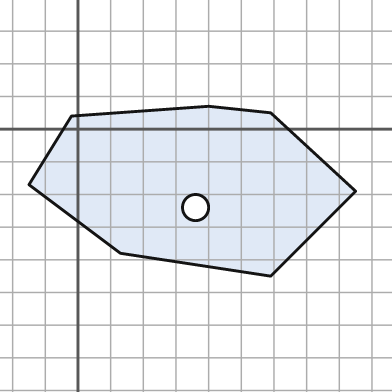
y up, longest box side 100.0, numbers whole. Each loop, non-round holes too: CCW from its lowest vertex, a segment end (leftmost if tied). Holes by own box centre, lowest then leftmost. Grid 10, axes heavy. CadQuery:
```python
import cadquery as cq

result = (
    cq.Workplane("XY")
    .moveTo(59.0, -45.0)
    .lineTo(85.0, -19.0)
    .lineTo(59.0, 5.0)
    .lineTo(40.0, 7.0)
    .lineTo(-2.0, 4.0)
    .lineTo(-15.0, -17.0)
    .lineTo(13.0, -38.0)
    .close()
    .moveTo(36.0, -24.0)
    .circle(4.0)
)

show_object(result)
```